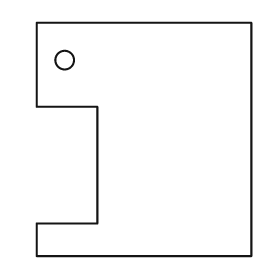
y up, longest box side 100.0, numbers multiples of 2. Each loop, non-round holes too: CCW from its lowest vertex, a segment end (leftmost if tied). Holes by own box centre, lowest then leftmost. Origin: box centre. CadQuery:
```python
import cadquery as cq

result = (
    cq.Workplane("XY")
    .moveTo(-46.0, -50.0)
    .lineTo(46.0, -50.0)
    .lineTo(46.0, 50.0)
    .lineTo(-46.0, 50.0)
    .lineTo(-46.0, 14.0)
    .lineTo(-20.0, 14.0)
    .lineTo(-20.0, -36.0)
    .lineTo(-46.0, -36.0)
    .close()
    .moveTo(-34.0, 34.0)
    .circle(4.0)
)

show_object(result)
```